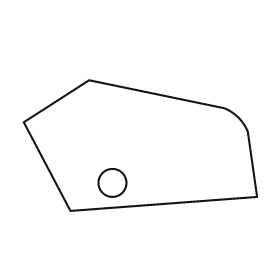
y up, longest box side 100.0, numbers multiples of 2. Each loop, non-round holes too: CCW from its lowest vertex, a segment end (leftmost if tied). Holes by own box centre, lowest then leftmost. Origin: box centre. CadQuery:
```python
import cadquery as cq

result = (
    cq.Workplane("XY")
    .moveTo(-30.0, -28.0)
    .lineTo(50.0, -22.0)
    .lineTo(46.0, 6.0)
    .threePointArc((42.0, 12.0), (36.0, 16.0))
    .lineTo(-22.0, 28.0)
    .lineTo(-50.0, 10.0)
    .close()
    .moveTo(-12.0, -16.0)
    .circle(6.0)
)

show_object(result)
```